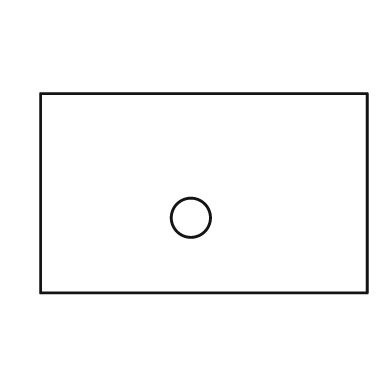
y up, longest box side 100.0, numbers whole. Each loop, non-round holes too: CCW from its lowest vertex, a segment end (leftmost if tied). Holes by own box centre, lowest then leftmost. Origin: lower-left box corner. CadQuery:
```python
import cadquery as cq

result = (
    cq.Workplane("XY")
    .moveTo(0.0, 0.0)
    .lineTo(100.0, 0.0)
    .lineTo(100.0, 61.0)
    .lineTo(0.0, 61.0)
    .close()
    .moveTo(46.0, 23.0)
    .circle(6.0)
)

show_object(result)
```